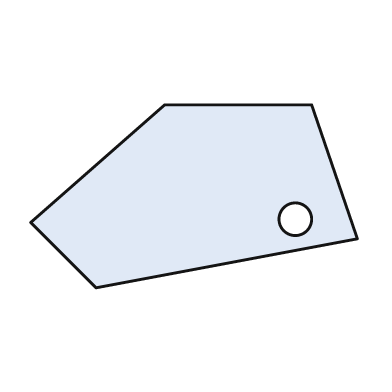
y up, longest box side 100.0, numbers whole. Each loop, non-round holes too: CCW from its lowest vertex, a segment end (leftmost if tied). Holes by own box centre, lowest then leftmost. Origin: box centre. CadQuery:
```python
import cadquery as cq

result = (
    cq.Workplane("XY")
    .moveTo(-30.0, -28.0)
    .lineTo(50.0, -13.0)
    .lineTo(36.0, 28.0)
    .lineTo(-9.0, 28.0)
    .lineTo(-50.0, -8.0)
    .close()
    .moveTo(31.0, -7.0)
    .circle(5.0)
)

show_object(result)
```